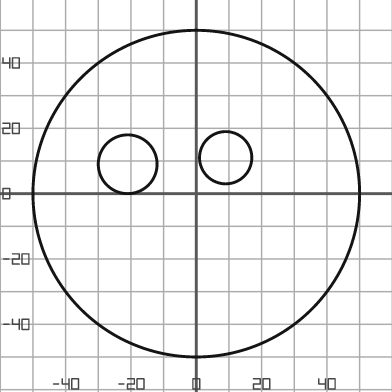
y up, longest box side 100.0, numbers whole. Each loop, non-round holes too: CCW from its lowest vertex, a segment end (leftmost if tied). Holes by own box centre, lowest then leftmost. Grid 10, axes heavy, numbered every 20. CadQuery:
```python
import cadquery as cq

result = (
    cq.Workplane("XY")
    .moveTo(0.0, 0.0)
    .circle(50.0)
    .moveTo(-21.0, 9.0)
    .circle(9.0)
    .moveTo(9.0, 11.0)
    .circle(8.0)
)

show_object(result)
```